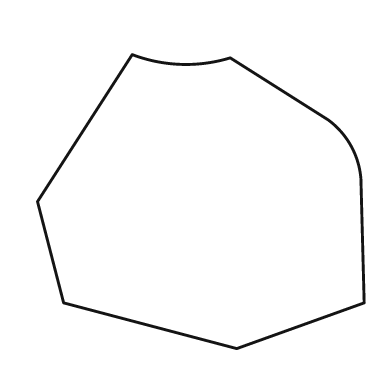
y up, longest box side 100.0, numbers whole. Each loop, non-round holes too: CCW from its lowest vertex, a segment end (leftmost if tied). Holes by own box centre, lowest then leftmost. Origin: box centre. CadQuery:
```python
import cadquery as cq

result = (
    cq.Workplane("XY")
    .moveTo(11.0, -45.0)
    .lineTo(50.0, -31.0)
    .lineTo(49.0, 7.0)
    .threePointArc((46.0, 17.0), (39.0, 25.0))
    .lineTo(9.0, 44.0)
    .threePointArc((-6.0, 42.0), (-21.0, 45.0))
    .lineTo(-50.0, 0.0)
    .lineTo(-42.0, -31.0)
    .close()
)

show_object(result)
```